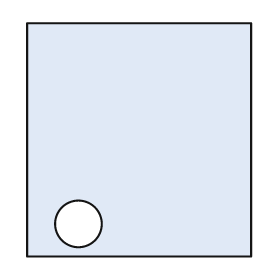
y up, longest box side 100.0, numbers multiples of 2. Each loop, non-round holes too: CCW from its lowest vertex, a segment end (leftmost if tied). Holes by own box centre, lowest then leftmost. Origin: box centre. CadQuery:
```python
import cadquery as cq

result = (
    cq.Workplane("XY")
    .moveTo(-48.0, -50.0)
    .lineTo(48.0, -50.0)
    .lineTo(48.0, 50.0)
    .lineTo(-48.0, 50.0)
    .close()
    .moveTo(-26.0, -36.0)
    .circle(10.0)
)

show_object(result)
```